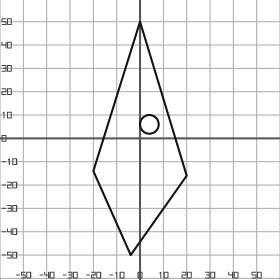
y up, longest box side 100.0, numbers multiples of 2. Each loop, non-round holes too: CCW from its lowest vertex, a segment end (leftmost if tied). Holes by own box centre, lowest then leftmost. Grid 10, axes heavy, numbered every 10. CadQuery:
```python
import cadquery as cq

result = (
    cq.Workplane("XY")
    .moveTo(-4.0, -50.0)
    .lineTo(20.0, -16.0)
    .lineTo(0.0, 50.0)
    .lineTo(-20.0, -14.0)
    .close()
    .moveTo(4.0, 6.0)
    .circle(4.0)
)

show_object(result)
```